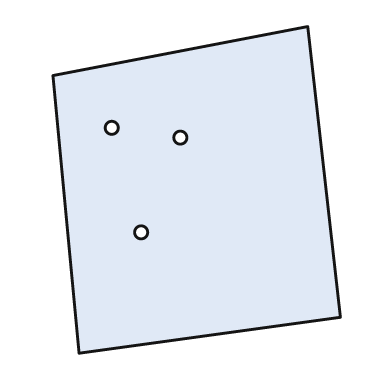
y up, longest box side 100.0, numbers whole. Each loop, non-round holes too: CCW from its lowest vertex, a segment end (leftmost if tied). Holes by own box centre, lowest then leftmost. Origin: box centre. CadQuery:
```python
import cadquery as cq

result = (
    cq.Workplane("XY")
    .moveTo(-36.0, -50.0)
    .lineTo(44.0, -39.0)
    .lineTo(34.0, 50.0)
    .lineTo(-44.0, 35.0)
    .close()
    .moveTo(-17.0, -13.0)
    .circle(2.0)
    .moveTo(-5.0, 16.0)
    .circle(2.0)
    .moveTo(-26.0, 19.0)
    .circle(2.0)
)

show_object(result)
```